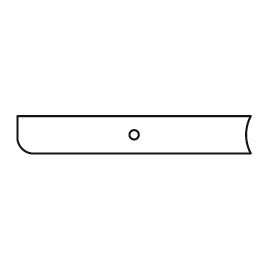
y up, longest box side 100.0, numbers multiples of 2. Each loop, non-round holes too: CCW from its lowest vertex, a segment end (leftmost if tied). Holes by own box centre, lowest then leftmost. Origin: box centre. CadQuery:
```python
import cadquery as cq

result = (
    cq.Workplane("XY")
    .moveTo(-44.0, -8.0)
    .lineTo(50.0, -8.0)
    .threePointArc((48.0, 0.0), (50.0, 8.0))
    .lineTo(-50.0, 8.0)
    .lineTo(-50.0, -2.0)
    .threePointArc((-48.0, -6.0), (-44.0, -8.0))
    .close()
    .moveTo(0.0, 0.0)
    .circle(2.0)
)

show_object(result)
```